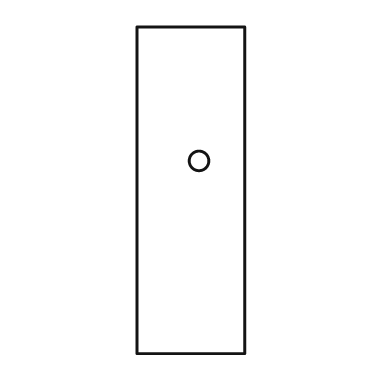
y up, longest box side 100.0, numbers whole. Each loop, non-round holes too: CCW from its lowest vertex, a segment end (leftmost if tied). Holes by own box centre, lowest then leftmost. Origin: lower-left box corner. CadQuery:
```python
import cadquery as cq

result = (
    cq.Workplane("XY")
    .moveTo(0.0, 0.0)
    .lineTo(33.0, 0.0)
    .lineTo(33.0, 100.0)
    .lineTo(0.0, 100.0)
    .close()
    .moveTo(19.0, 59.0)
    .circle(3.0)
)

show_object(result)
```